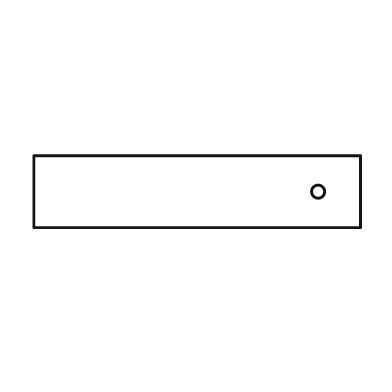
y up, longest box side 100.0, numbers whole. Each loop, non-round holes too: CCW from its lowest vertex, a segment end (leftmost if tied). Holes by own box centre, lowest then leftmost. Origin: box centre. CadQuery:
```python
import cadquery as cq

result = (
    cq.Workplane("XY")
    .moveTo(-50.0, -11.0)
    .lineTo(50.0, -11.0)
    .lineTo(50.0, 11.0)
    .lineTo(-50.0, 11.0)
    .close()
    .moveTo(37.0, 0.0)
    .circle(2.0)
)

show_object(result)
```